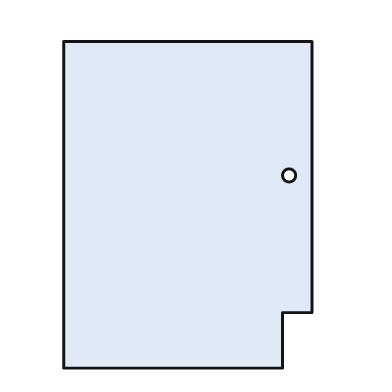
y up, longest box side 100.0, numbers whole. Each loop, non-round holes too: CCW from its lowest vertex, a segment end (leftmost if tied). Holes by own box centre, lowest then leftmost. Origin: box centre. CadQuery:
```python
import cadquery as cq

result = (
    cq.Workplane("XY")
    .moveTo(-38.0, -50.0)
    .lineTo(29.0, -50.0)
    .lineTo(29.0, -33.0)
    .lineTo(38.0, -33.0)
    .lineTo(38.0, 50.0)
    .lineTo(-38.0, 50.0)
    .close()
    .moveTo(31.0, 9.0)
    .circle(2.0)
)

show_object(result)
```